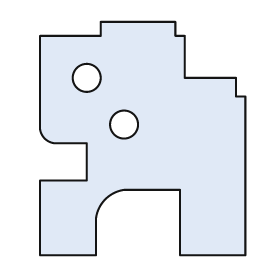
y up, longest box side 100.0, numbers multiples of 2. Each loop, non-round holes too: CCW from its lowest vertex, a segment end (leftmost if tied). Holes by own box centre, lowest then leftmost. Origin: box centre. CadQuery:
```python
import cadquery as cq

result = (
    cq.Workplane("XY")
    .moveTo(-44.0, -50.0)
    .lineTo(-20.0, -50.0)
    .lineTo(-20.0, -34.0)
    .threePointArc((-16.0, -26.0), (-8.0, -22.0))
    .lineTo(16.0, -22.0)
    .lineTo(16.0, -50.0)
    .lineTo(44.0, -50.0)
    .lineTo(44.0, 18.0)
    .lineTo(40.0, 18.0)
    .lineTo(40.0, 26.0)
    .lineTo(18.0, 26.0)
    .lineTo(18.0, 44.0)
    .lineTo(14.0, 44.0)
    .lineTo(14.0, 50.0)
    .lineTo(-18.0, 50.0)
    .lineTo(-18.0, 44.0)
    .lineTo(-44.0, 44.0)
    .lineTo(-44.0, 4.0)
    .threePointArc((-42.0, 0.0), (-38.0, -2.0))
    .lineTo(-24.0, -2.0)
    .lineTo(-24.0, -18.0)
    .lineTo(-44.0, -18.0)
    .close()
    .moveTo(-8.0, 6.0)
    .circle(6.0)
    .moveTo(-24.0, 26.0)
    .circle(6.0)
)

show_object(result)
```